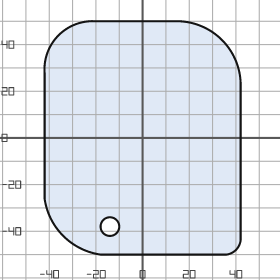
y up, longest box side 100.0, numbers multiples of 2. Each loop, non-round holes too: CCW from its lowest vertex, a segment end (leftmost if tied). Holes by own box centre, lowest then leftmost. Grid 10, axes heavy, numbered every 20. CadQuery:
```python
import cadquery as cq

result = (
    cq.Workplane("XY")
    .moveTo(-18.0, -50.0)
    .lineTo(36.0, -50.0)
    .threePointArc((40.0, -48.0), (42.0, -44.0))
    .lineTo(42.0, 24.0)
    .threePointArc((34.0, 42.0), (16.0, 50.0))
    .lineTo(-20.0, 50.0)
    .threePointArc((-36.0, 44.0), (-42.0, 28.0))
    .lineTo(-42.0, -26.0)
    .threePointArc((-34.0, -42.0), (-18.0, -50.0))
    .close()
    .moveTo(-14.0, -38.0)
    .circle(4.0)
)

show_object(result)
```